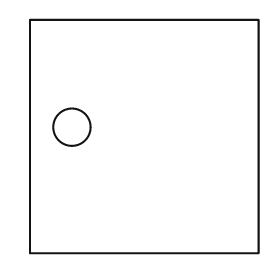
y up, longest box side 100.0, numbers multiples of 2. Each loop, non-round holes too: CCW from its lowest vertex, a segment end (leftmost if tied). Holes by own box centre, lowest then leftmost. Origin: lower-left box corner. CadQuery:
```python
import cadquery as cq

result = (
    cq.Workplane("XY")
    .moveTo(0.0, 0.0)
    .lineTo(98.0, 0.0)
    .lineTo(98.0, 100.0)
    .lineTo(0.0, 100.0)
    .close()
    .moveTo(18.0, 54.0)
    .circle(8.0)
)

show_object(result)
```